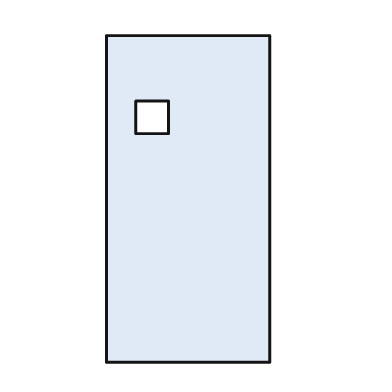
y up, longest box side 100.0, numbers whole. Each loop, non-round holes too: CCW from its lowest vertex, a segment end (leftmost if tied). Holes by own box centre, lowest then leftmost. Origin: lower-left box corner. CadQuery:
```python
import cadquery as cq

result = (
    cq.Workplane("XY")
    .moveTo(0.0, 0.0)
    .lineTo(50.0, 0.0)
    .lineTo(50.0, 100.0)
    .lineTo(0.0, 100.0)
    .close()
    .moveTo(9.0, 70.0)
    .lineTo(19.0, 70.0)
    .lineTo(19.0, 80.0)
    .lineTo(9.0, 80.0)
    .close()
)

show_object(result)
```